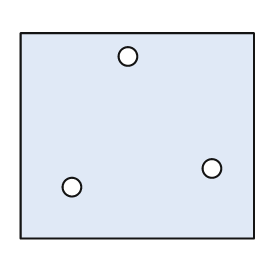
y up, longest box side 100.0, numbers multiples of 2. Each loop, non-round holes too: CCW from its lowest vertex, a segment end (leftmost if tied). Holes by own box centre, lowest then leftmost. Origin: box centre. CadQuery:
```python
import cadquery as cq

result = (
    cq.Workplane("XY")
    .moveTo(-50.0, -44.0)
    .lineTo(50.0, -44.0)
    .lineTo(50.0, 44.0)
    .lineTo(-50.0, 44.0)
    .close()
    .moveTo(-28.0, -22.0)
    .circle(4.0)
    .moveTo(32.0, -14.0)
    .circle(4.0)
    .moveTo(-4.0, 34.0)
    .circle(4.0)
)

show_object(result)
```